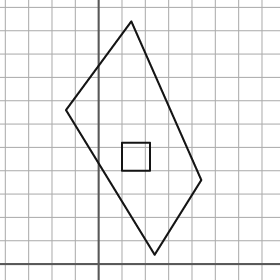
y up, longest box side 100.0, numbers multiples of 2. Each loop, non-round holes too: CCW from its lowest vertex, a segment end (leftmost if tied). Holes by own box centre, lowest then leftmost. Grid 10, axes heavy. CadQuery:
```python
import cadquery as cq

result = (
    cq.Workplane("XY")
    .moveTo(24.0, 4.0)
    .lineTo(44.0, 36.0)
    .lineTo(14.0, 104.0)
    .lineTo(-14.0, 66.0)
    .close()
    .moveTo(10.0, 40.0)
    .lineTo(22.0, 40.0)
    .lineTo(22.0, 52.0)
    .lineTo(10.0, 52.0)
    .close()
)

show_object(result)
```